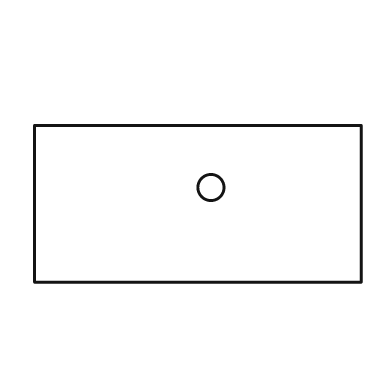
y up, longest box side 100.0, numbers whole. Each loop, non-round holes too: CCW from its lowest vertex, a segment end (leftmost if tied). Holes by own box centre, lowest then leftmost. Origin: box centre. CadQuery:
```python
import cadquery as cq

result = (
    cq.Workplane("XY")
    .moveTo(-50.0, -24.0)
    .lineTo(50.0, -24.0)
    .lineTo(50.0, 24.0)
    .lineTo(-50.0, 24.0)
    .close()
    .moveTo(4.0, 5.0)
    .circle(4.0)
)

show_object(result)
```